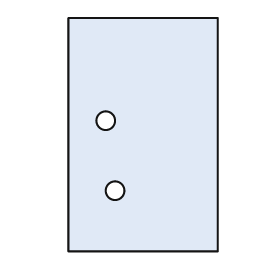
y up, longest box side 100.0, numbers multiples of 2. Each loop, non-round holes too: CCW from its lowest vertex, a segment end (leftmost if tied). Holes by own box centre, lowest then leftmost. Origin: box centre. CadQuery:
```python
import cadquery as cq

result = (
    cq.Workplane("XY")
    .moveTo(-32.0, -50.0)
    .lineTo(32.0, -50.0)
    .lineTo(32.0, 50.0)
    .lineTo(-32.0, 50.0)
    .close()
    .moveTo(-12.0, -24.0)
    .circle(4.0)
    .moveTo(-16.0, 6.0)
    .circle(4.0)
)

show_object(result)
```